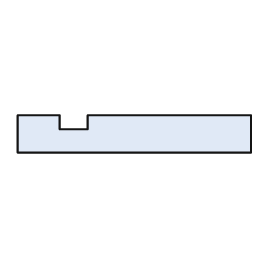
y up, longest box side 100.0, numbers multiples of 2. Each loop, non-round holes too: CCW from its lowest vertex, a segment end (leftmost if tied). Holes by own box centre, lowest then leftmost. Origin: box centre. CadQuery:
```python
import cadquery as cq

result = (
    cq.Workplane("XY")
    .moveTo(-50.0, -8.0)
    .lineTo(50.0, -8.0)
    .lineTo(50.0, 8.0)
    .lineTo(-20.0, 8.0)
    .lineTo(-20.0, 2.0)
    .lineTo(-32.0, 2.0)
    .lineTo(-32.0, 8.0)
    .lineTo(-50.0, 8.0)
    .close()
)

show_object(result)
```